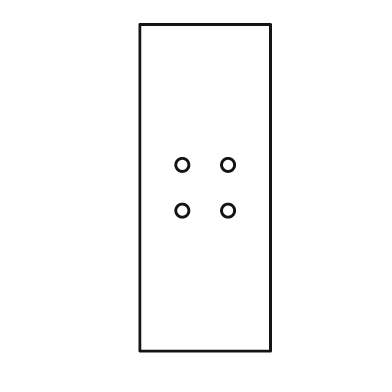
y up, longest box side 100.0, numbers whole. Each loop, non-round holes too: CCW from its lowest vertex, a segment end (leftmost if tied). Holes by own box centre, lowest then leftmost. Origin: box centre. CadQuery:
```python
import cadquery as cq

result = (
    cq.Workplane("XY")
    .moveTo(-20.0, -50.0)
    .lineTo(20.0, -50.0)
    .lineTo(20.0, 50.0)
    .lineTo(-20.0, 50.0)
    .close()
    .moveTo(-7.0, -7.0)
    .circle(2.0)
    .moveTo(7.0, -7.0)
    .circle(2.0)
    .moveTo(-7.0, 7.0)
    .circle(2.0)
    .moveTo(7.0, 7.0)
    .circle(2.0)
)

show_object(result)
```